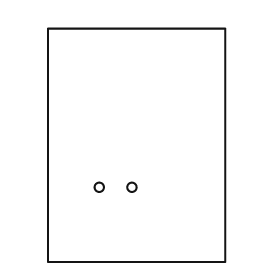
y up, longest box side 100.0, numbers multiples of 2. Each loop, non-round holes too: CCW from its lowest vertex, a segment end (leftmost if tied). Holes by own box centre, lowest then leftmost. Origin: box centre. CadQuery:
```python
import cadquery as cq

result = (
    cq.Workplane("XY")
    .moveTo(-38.0, -50.0)
    .lineTo(38.0, -50.0)
    .lineTo(38.0, 50.0)
    .lineTo(-38.0, 50.0)
    .close()
    .moveTo(-16.0, -18.0)
    .circle(2.0)
    .moveTo(-2.0, -18.0)
    .circle(2.0)
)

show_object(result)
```